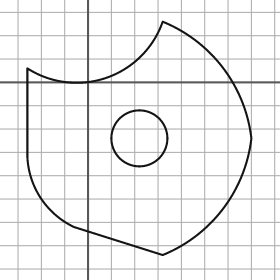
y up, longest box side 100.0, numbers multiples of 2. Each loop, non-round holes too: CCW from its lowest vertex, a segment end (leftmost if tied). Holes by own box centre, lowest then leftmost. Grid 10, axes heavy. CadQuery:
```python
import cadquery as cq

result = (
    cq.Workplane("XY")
    .moveTo(32.0, -74.0)
    .threePointArc((58.0, -54.0), (70.0, -24.0))
    .threePointArc((58.0, 6.0), (32.0, 26.0))
    .threePointArc((8.0, 2.0), (-26.0, 6.0))
    .lineTo(-26.0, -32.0)
    .threePointArc((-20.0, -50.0), (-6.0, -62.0))
    .close()
    .moveTo(22.0, -24.0)
    .circle(12.0)
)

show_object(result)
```